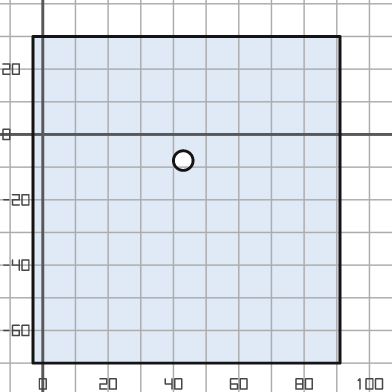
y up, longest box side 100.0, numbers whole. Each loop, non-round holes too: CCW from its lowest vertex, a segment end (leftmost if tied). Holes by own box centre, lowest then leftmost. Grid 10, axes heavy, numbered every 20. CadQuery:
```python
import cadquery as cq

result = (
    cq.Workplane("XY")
    .moveTo(-3.0, -70.0)
    .lineTo(91.0, -70.0)
    .lineTo(91.0, 30.0)
    .lineTo(-3.0, 30.0)
    .close()
    .moveTo(43.0, -8.0)
    .circle(3.0)
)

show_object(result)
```